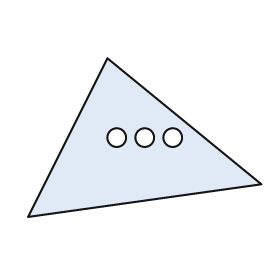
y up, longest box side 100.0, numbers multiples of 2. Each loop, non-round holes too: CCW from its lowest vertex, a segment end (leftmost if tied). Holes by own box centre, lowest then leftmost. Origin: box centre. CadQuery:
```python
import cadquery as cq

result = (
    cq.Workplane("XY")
    .moveTo(-50.0, -34.0)
    .lineTo(50.0, -20.0)
    .lineTo(-16.0, 34.0)
    .close()
    .moveTo(-12.0, 0.0)
    .circle(4.0)
    .moveTo(0.0, 0.0)
    .circle(4.0)
    .moveTo(12.0, 0.0)
    .circle(4.0)
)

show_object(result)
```